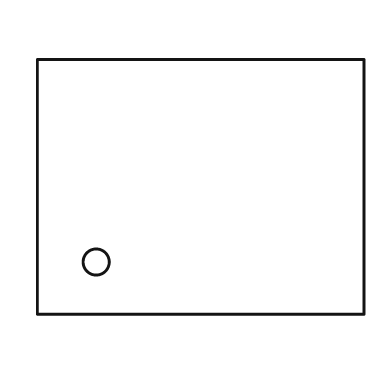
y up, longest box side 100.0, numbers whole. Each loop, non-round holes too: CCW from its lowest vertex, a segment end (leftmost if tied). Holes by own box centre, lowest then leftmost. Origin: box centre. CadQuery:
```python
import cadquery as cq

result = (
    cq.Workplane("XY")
    .moveTo(-50.0, -39.0)
    .lineTo(50.0, -39.0)
    .lineTo(50.0, 39.0)
    .lineTo(-50.0, 39.0)
    .close()
    .moveTo(-32.0, -23.0)
    .circle(4.0)
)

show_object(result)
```